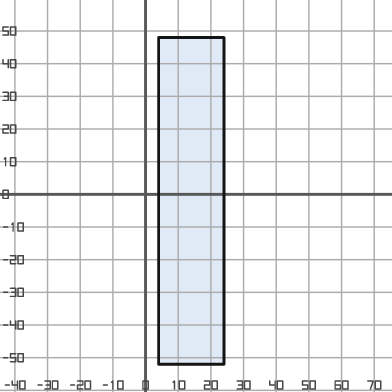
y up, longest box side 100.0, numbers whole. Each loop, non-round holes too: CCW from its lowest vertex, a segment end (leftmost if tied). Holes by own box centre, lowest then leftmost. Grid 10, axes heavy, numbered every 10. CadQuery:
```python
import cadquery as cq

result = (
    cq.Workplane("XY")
    .moveTo(4.0, -52.0)
    .lineTo(24.0, -52.0)
    .lineTo(24.0, 48.0)
    .lineTo(4.0, 48.0)
    .close()
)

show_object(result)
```